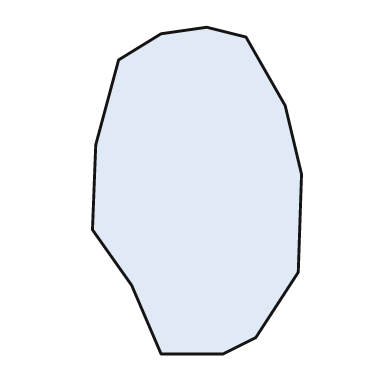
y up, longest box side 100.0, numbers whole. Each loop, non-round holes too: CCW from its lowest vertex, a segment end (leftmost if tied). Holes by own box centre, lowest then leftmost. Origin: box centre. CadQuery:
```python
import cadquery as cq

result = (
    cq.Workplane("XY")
    .moveTo(-11.0, -50.0)
    .lineTo(8.0, -50.0)
    .lineTo(18.0, -45.0)
    .lineTo(31.0, -25.0)
    .lineTo(32.0, 5.0)
    .lineTo(27.0, 26.0)
    .lineTo(15.0, 47.0)
    .lineTo(3.0, 50.0)
    .lineTo(-11.0, 48.0)
    .lineTo(-24.0, 40.0)
    .lineTo(-31.0, 14.0)
    .lineTo(-32.0, -12.0)
    .lineTo(-20.0, -29.0)
    .close()
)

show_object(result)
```